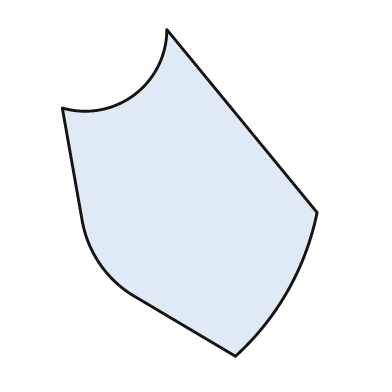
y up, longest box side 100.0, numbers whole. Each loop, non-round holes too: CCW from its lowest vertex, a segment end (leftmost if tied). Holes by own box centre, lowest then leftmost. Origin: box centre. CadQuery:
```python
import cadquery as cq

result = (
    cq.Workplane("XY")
    .moveTo(14.0, -50.0)
    .threePointArc((30.0, -30.0), (39.0, -6.0))
    .lineTo(-7.0, 50.0)
    .threePointArc((-17.0, 30.0), (-39.0, 26.0))
    .lineTo(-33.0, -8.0)
    .threePointArc((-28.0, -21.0), (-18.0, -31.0))
    .close()
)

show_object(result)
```